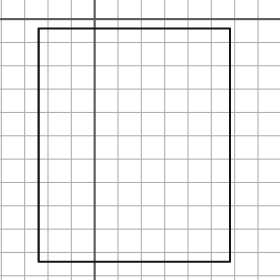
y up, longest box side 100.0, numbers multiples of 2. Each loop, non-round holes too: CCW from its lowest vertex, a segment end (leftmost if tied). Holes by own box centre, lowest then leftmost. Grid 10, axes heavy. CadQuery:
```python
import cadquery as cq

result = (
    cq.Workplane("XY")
    .moveTo(-24.0, -104.0)
    .lineTo(58.0, -104.0)
    .lineTo(58.0, -4.0)
    .lineTo(-24.0, -4.0)
    .close()
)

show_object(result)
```